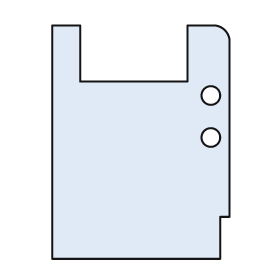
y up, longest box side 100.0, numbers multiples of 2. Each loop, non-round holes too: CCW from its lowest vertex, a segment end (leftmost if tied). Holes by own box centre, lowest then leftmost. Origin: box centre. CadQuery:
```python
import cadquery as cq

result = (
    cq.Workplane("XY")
    .moveTo(-38.0, -50.0)
    .lineTo(34.0, -50.0)
    .lineTo(34.0, -32.0)
    .lineTo(38.0, -32.0)
    .lineTo(38.0, 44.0)
    .threePointArc((36.0, 48.0), (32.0, 50.0))
    .lineTo(20.0, 50.0)
    .lineTo(20.0, 26.0)
    .lineTo(-26.0, 26.0)
    .lineTo(-26.0, 50.0)
    .lineTo(-38.0, 50.0)
    .close()
    .moveTo(30.0, 2.0)
    .circle(4.0)
    .moveTo(30.0, 20.0)
    .circle(4.0)
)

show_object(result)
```